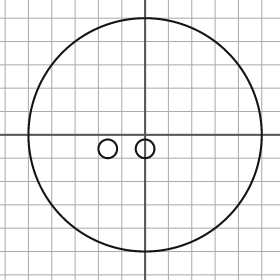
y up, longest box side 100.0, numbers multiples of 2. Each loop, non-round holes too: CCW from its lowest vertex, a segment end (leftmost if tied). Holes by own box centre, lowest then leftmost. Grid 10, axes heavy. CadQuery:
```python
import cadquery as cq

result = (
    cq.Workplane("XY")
    .moveTo(0.0, 0.0)
    .circle(50.0)
    .moveTo(-16.0, -6.0)
    .circle(4.0)
    .moveTo(0.0, -6.0)
    .circle(4.0)
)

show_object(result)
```